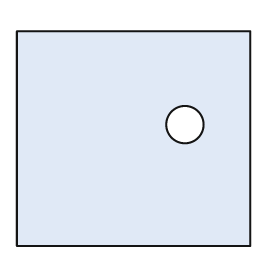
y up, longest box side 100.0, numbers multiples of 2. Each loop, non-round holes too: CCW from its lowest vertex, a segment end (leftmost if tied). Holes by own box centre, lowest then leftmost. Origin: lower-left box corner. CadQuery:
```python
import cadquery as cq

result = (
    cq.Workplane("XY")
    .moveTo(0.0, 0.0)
    .lineTo(100.0, 0.0)
    .lineTo(100.0, 92.0)
    .lineTo(0.0, 92.0)
    .close()
    .moveTo(72.0, 52.0)
    .circle(8.0)
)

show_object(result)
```